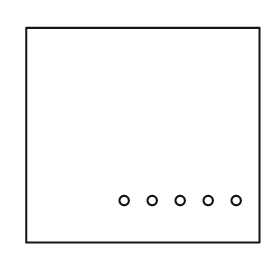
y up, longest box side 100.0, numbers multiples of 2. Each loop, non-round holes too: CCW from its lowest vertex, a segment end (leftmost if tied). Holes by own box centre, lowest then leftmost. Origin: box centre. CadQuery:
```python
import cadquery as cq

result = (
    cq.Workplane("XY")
    .moveTo(-50.0, -46.0)
    .lineTo(50.0, -46.0)
    .lineTo(50.0, 46.0)
    .lineTo(-50.0, 46.0)
    .close()
    .moveTo(-8.0, -28.0)
    .circle(2.0)
    .moveTo(4.0, -28.0)
    .circle(2.0)
    .moveTo(16.0, -28.0)
    .circle(2.0)
    .moveTo(28.0, -28.0)
    .circle(2.0)
    .moveTo(40.0, -28.0)
    .circle(2.0)
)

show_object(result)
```